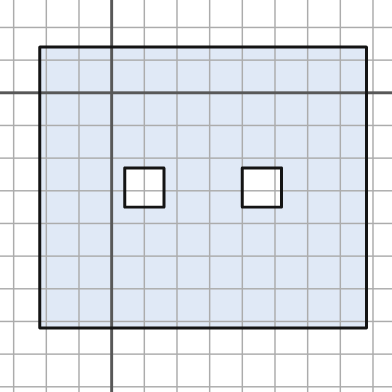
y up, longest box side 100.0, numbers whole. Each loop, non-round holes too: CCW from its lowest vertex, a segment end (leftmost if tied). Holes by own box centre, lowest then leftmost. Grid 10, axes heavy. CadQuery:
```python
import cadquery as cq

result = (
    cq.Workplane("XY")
    .moveTo(-22.0, -72.0)
    .lineTo(78.0, -72.0)
    .lineTo(78.0, 14.0)
    .lineTo(-22.0, 14.0)
    .close()
    .moveTo(4.0, -35.0)
    .lineTo(16.0, -35.0)
    .lineTo(16.0, -23.0)
    .lineTo(4.0, -23.0)
    .close()
    .moveTo(40.0, -35.0)
    .lineTo(52.0, -35.0)
    .lineTo(52.0, -23.0)
    .lineTo(40.0, -23.0)
    .close()
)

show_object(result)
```